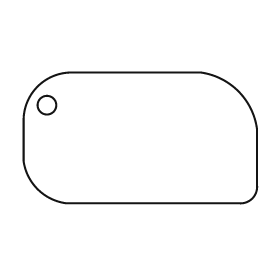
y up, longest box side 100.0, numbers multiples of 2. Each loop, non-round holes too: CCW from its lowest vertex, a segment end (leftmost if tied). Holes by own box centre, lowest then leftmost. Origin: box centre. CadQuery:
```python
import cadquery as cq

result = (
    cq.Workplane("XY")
    .moveTo(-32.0, -28.0)
    .lineTo(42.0, -28.0)
    .threePointArc((48.0, -26.0), (50.0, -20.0))
    .lineTo(50.0, 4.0)
    .threePointArc((42.0, 20.0), (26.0, 28.0))
    .lineTo(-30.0, 28.0)
    .threePointArc((-44.0, 22.0), (-50.0, 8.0))
    .lineTo(-50.0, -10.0)
    .threePointArc((-44.0, -22.0), (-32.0, -28.0))
    .close()
    .moveTo(-40.0, 14.0)
    .circle(4.0)
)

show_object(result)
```